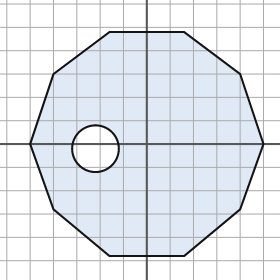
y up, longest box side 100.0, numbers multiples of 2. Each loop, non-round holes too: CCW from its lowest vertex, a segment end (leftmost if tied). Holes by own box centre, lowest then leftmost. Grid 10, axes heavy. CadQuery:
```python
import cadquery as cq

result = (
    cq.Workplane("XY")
    .moveTo(-16.0, -48.0)
    .lineTo(16.0, -48.0)
    .lineTo(40.0, -28.0)
    .lineTo(50.0, 0.0)
    .lineTo(40.0, 30.0)
    .lineTo(16.0, 48.0)
    .lineTo(-16.0, 48.0)
    .lineTo(-40.0, 30.0)
    .lineTo(-50.0, 0.0)
    .lineTo(-40.0, -28.0)
    .close()
    .moveTo(-22.0, -2.0)
    .circle(10.0)
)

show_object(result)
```